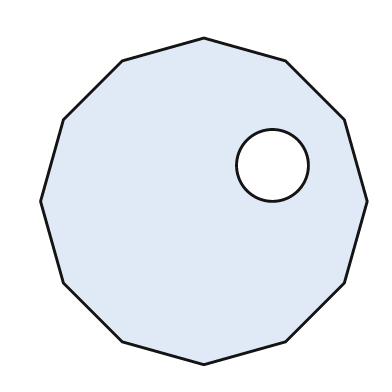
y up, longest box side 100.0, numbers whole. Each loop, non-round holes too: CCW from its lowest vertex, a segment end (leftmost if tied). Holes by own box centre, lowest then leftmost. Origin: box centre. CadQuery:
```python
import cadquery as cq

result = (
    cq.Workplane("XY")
    .moveTo(0.0, -50.0)
    .lineTo(25.0, -43.0)
    .lineTo(43.0, -25.0)
    .lineTo(50.0, 0.0)
    .lineTo(43.0, 25.0)
    .lineTo(25.0, 43.0)
    .lineTo(0.0, 50.0)
    .lineTo(-25.0, 43.0)
    .lineTo(-43.0, 25.0)
    .lineTo(-50.0, 0.0)
    .lineTo(-43.0, -25.0)
    .lineTo(-25.0, -43.0)
    .close()
    .moveTo(21.0, 11.0)
    .circle(11.0)
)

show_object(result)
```